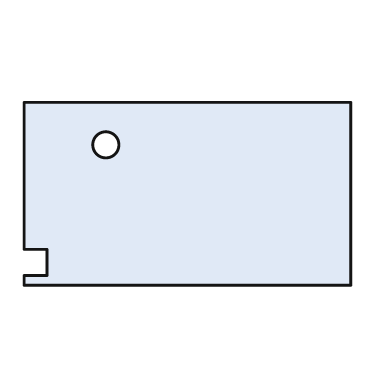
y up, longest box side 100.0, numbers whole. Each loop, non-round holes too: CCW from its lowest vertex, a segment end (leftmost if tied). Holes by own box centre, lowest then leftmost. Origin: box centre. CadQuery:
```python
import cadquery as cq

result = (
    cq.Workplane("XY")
    .moveTo(-50.0, -28.0)
    .lineTo(50.0, -28.0)
    .lineTo(50.0, 28.0)
    .lineTo(-50.0, 28.0)
    .lineTo(-50.0, -17.0)
    .lineTo(-43.0, -17.0)
    .lineTo(-43.0, -25.0)
    .lineTo(-50.0, -25.0)
    .close()
    .moveTo(-25.0, 15.0)
    .circle(4.0)
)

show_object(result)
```